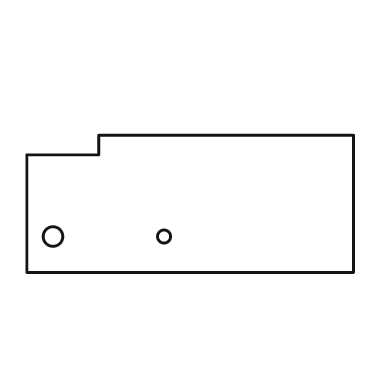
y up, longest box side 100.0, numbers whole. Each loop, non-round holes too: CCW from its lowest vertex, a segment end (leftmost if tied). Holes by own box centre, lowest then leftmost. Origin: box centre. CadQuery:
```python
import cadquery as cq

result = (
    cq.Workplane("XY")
    .moveTo(-50.0, -21.0)
    .lineTo(50.0, -21.0)
    .lineTo(50.0, 21.0)
    .lineTo(-28.0, 21.0)
    .lineTo(-28.0, 15.0)
    .lineTo(-50.0, 15.0)
    .close()
    .moveTo(-42.0, -10.0)
    .circle(3.0)
    .moveTo(-8.0, -10.0)
    .circle(2.0)
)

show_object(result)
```